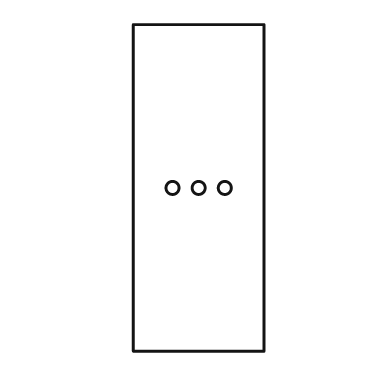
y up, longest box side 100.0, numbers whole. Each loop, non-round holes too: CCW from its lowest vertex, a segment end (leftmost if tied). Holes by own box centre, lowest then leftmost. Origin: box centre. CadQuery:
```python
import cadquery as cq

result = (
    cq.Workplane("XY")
    .moveTo(-20.0, -50.0)
    .lineTo(20.0, -50.0)
    .lineTo(20.0, 50.0)
    .lineTo(-20.0, 50.0)
    .close()
    .moveTo(-8.0, 0.0)
    .circle(2.0)
    .moveTo(0.0, 0.0)
    .circle(2.0)
    .moveTo(8.0, 0.0)
    .circle(2.0)
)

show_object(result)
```